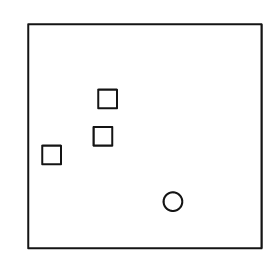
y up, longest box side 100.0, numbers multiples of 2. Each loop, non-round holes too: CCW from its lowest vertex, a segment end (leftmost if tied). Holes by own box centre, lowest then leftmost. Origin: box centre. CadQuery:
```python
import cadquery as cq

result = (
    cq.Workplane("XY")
    .moveTo(-50.0, -48.0)
    .lineTo(50.0, -48.0)
    .lineTo(50.0, 48.0)
    .lineTo(-50.0, 48.0)
    .close()
    .moveTo(12.0, -28.0)
    .circle(4.0)
    .moveTo(-44.0, -12.0)
    .lineTo(-36.0, -12.0)
    .lineTo(-36.0, -4.0)
    .lineTo(-44.0, -4.0)
    .close()
    .moveTo(-22.0, -4.0)
    .lineTo(-14.0, -4.0)
    .lineTo(-14.0, 4.0)
    .lineTo(-22.0, 4.0)
    .close()
    .moveTo(-20.0, 12.0)
    .lineTo(-12.0, 12.0)
    .lineTo(-12.0, 20.0)
    .lineTo(-20.0, 20.0)
    .close()
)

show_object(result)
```